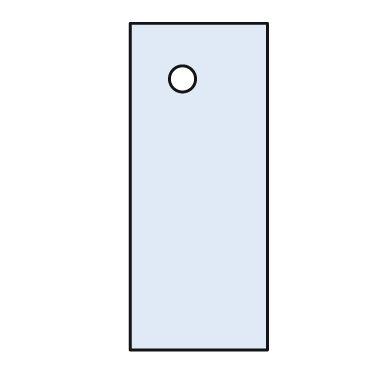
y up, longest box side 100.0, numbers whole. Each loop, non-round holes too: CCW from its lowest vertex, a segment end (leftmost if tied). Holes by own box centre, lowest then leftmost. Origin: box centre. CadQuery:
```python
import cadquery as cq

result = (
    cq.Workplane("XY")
    .moveTo(-21.0, -50.0)
    .lineTo(21.0, -50.0)
    .lineTo(21.0, 50.0)
    .lineTo(-21.0, 50.0)
    .close()
    .moveTo(-5.0, 33.0)
    .circle(4.0)
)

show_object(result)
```